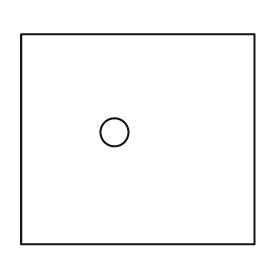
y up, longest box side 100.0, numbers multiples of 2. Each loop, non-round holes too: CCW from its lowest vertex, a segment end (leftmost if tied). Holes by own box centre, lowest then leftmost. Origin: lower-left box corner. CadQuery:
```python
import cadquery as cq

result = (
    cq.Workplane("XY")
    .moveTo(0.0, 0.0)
    .lineTo(100.0, 0.0)
    .lineTo(100.0, 90.0)
    .lineTo(0.0, 90.0)
    .close()
    .moveTo(40.0, 48.0)
    .circle(6.0)
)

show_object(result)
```